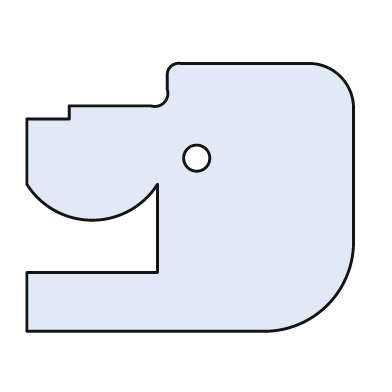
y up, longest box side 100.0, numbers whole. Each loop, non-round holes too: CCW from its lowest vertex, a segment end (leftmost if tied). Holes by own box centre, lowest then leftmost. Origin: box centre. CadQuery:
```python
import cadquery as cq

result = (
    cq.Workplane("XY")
    .moveTo(-50.0, -41.0)
    .lineTo(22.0, -41.0)
    .threePointArc((42.0, -33.0), (50.0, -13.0))
    .lineTo(50.0, 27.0)
    .threePointArc((46.0, 37.0), (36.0, 41.0))
    .lineTo(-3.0, 41.0)
    .threePointArc((-6.0, 40.0), (-7.0, 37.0))
    .lineTo(-7.0, 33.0)
    .threePointArc((-8.0, 29.0), (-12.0, 28.0))
    .lineTo(-37.0, 28.0)
    .lineTo(-37.0, 24.0)
    .lineTo(-50.0, 24.0)
    .lineTo(-50.0, 4.0)
    .threePointArc((-30.0, -7.0), (-10.0, 4.0))
    .lineTo(-10.0, -23.0)
    .lineTo(-50.0, -23.0)
    .close()
    .moveTo(2.0, 12.0)
    .circle(4.0)
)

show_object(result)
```